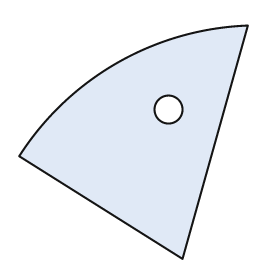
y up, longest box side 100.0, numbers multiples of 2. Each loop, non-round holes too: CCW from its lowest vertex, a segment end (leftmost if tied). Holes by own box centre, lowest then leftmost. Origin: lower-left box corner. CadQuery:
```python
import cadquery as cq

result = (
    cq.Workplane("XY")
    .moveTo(70.0, 0.0)
    .lineTo(98.0, 100.0)
    .threePointArc((42.0, 84.0), (0.0, 44.0))
    .close()
    .moveTo(64.0, 64.0)
    .circle(6.0)
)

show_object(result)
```